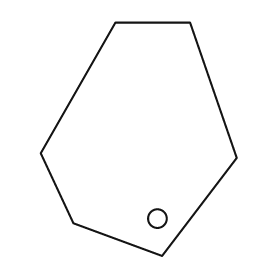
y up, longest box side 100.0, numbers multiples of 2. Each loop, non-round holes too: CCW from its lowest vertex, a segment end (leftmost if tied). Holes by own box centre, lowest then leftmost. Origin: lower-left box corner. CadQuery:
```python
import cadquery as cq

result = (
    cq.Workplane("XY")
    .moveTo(52.0, 0.0)
    .lineTo(84.0, 42.0)
    .lineTo(64.0, 100.0)
    .lineTo(32.0, 100.0)
    .lineTo(0.0, 44.0)
    .lineTo(14.0, 14.0)
    .close()
    .moveTo(50.0, 16.0)
    .circle(4.0)
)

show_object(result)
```